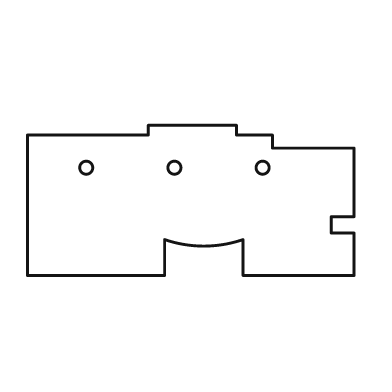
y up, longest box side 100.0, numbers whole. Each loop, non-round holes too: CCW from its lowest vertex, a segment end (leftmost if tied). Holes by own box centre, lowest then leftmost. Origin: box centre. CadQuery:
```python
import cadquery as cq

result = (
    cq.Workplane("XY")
    .moveTo(-50.0, -23.0)
    .lineTo(-8.0, -23.0)
    .lineTo(-8.0, -12.0)
    .threePointArc((4.0, -14.0), (16.0, -12.0))
    .lineTo(16.0, -23.0)
    .lineTo(50.0, -23.0)
    .lineTo(50.0, -10.0)
    .lineTo(43.0, -10.0)
    .lineTo(43.0, -5.0)
    .lineTo(50.0, -5.0)
    .lineTo(50.0, 16.0)
    .lineTo(25.0, 16.0)
    .lineTo(25.0, 20.0)
    .lineTo(14.0, 20.0)
    .lineTo(14.0, 23.0)
    .lineTo(-13.0, 23.0)
    .lineTo(-13.0, 20.0)
    .lineTo(-50.0, 20.0)
    .close()
    .moveTo(-32.0, 10.0)
    .circle(2.0)
    .moveTo(-5.0, 10.0)
    .circle(2.0)
    .moveTo(22.0, 10.0)
    .circle(2.0)
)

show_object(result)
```